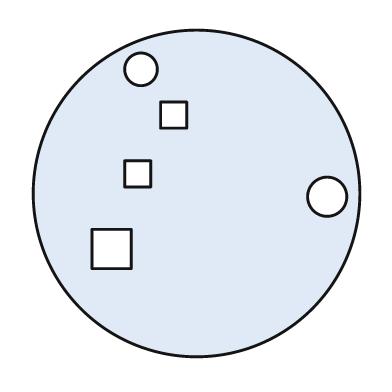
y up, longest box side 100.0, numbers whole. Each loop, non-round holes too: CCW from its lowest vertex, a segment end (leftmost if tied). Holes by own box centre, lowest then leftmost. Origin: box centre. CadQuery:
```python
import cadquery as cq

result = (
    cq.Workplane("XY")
    .moveTo(0.0, 0.0)
    .circle(50.0)
    .moveTo(-32.0, -23.0)
    .lineTo(-20.0, -23.0)
    .lineTo(-20.0, -11.0)
    .lineTo(-32.0, -11.0)
    .close()
    .moveTo(40.0, -1.0)
    .circle(6.0)
    .moveTo(-22.0, 2.0)
    .lineTo(-14.0, 2.0)
    .lineTo(-14.0, 10.0)
    .lineTo(-22.0, 10.0)
    .close()
    .moveTo(-11.0, 20.0)
    .lineTo(-3.0, 20.0)
    .lineTo(-3.0, 28.0)
    .lineTo(-11.0, 28.0)
    .close()
    .moveTo(-17.0, 38.0)
    .circle(5.0)
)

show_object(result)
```